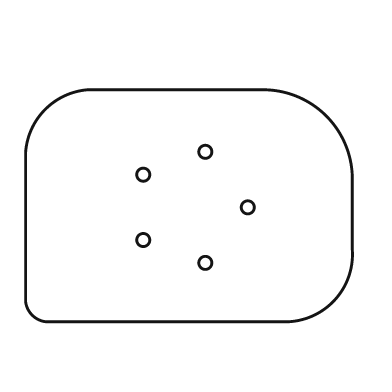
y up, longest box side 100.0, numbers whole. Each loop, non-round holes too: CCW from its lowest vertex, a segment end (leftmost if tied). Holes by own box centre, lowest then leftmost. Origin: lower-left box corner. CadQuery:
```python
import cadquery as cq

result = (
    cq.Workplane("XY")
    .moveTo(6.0, 0.0)
    .lineTo(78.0, 0.0)
    .threePointArc((94.0, 6.0), (100.0, 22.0))
    .lineTo(100.0, 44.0)
    .threePointArc((92.0, 63.0), (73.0, 71.0))
    .lineTo(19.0, 71.0)
    .threePointArc((6.0, 65.0), (0.0, 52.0))
    .lineTo(0.0, 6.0)
    .threePointArc((2.0, 2.0), (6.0, 0.0))
    .close()
    .moveTo(55.0, 18.0)
    .circle(2.0)
    .moveTo(36.0, 25.0)
    .circle(2.0)
    .moveTo(68.0, 35.0)
    .circle(2.0)
    .moveTo(36.0, 45.0)
    .circle(2.0)
    .moveTo(55.0, 52.0)
    .circle(2.0)
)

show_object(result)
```